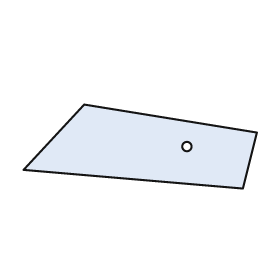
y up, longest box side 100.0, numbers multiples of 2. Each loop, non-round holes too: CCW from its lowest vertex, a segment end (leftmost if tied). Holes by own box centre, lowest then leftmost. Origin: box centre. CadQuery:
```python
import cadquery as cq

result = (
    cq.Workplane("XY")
    .moveTo(44.0, -18.0)
    .lineTo(50.0, 6.0)
    .lineTo(-24.0, 18.0)
    .lineTo(-50.0, -10.0)
    .close()
    .moveTo(20.0, 0.0)
    .circle(2.0)
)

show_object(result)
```